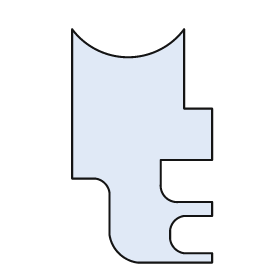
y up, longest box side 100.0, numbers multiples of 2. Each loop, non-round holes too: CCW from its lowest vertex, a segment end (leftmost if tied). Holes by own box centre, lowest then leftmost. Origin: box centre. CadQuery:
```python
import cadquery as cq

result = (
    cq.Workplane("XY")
    .moveTo(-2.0, -50.0)
    .lineTo(30.0, -50.0)
    .lineTo(30.0, -46.0)
    .lineTo(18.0, -46.0)
    .threePointArc((14.0, -44.0), (12.0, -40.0))
    .lineTo(12.0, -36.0)
    .threePointArc((14.0, -32.0), (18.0, -30.0))
    .lineTo(30.0, -30.0)
    .lineTo(30.0, -24.0)
    .lineTo(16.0, -24.0)
    .threePointArc((10.0, -22.0), (8.0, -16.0))
    .lineTo(8.0, -6.0)
    .lineTo(30.0, -6.0)
    .lineTo(30.0, 16.0)
    .lineTo(18.0, 16.0)
    .lineTo(18.0, 50.0)
    .threePointArc((-6.0, 38.0), (-30.0, 50.0))
    .lineTo(-30.0, -14.0)
    .lineTo(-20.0, -14.0)
    .threePointArc((-16.0, -16.0), (-14.0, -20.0))
    .lineTo(-14.0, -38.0)
    .threePointArc((-10.0, -46.0), (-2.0, -50.0))
    .close()
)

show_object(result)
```